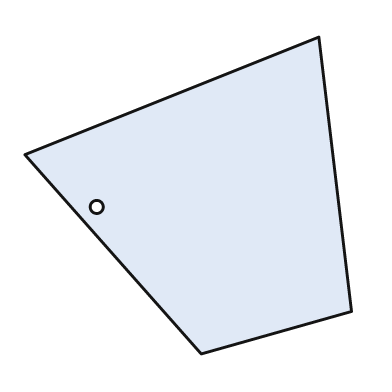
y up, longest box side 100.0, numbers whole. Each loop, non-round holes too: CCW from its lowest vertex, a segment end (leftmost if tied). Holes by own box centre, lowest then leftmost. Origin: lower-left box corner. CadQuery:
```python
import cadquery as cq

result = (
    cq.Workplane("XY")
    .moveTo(54.0, 0.0)
    .lineTo(100.0, 13.0)
    .lineTo(90.0, 97.0)
    .lineTo(0.0, 61.0)
    .close()
    .moveTo(22.0, 45.0)
    .circle(2.0)
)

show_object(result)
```